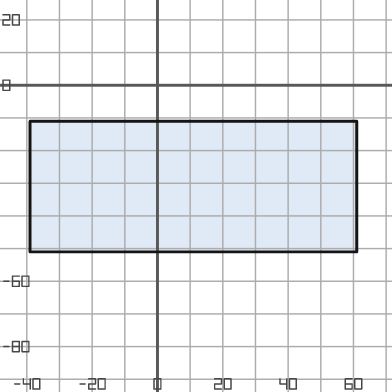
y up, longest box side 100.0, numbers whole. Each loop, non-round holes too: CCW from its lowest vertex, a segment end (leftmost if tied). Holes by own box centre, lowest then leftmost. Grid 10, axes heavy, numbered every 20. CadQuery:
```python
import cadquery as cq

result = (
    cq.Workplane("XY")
    .moveTo(-39.0, -51.0)
    .lineTo(61.0, -51.0)
    .lineTo(61.0, -11.0)
    .lineTo(-39.0, -11.0)
    .close()
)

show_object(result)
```